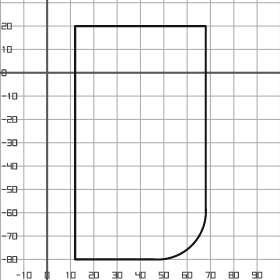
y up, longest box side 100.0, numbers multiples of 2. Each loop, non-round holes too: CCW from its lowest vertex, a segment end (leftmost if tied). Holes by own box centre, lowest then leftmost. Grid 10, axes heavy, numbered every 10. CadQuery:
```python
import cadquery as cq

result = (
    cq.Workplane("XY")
    .moveTo(12.0, -80.0)
    .lineTo(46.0, -80.0)
    .threePointArc((62.0, -74.0), (68.0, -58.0))
    .lineTo(68.0, 20.0)
    .lineTo(12.0, 20.0)
    .close()
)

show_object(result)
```